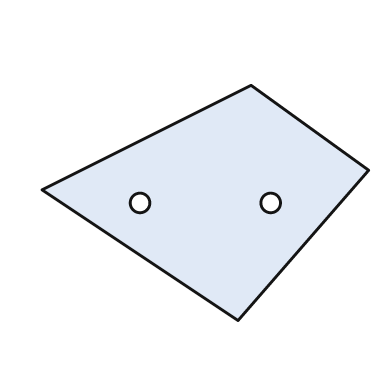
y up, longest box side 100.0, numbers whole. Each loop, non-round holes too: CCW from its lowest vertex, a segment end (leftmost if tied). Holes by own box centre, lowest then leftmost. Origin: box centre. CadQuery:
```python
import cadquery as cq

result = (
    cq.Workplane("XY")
    .moveTo(10.0, -36.0)
    .lineTo(50.0, 10.0)
    .lineTo(14.0, 36.0)
    .lineTo(-50.0, 4.0)
    .close()
    .moveTo(-20.0, 0.0)
    .circle(3.0)
    .moveTo(20.0, 0.0)
    .circle(3.0)
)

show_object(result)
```